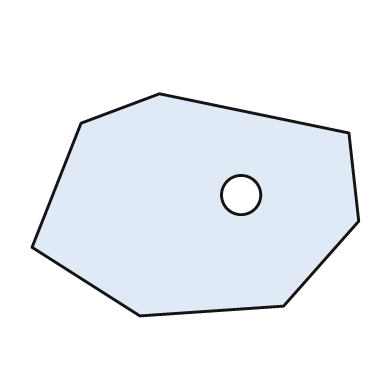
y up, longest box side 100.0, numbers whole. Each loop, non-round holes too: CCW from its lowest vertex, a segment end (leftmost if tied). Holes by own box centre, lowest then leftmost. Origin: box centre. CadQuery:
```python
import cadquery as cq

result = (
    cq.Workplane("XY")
    .moveTo(-17.0, -34.0)
    .lineTo(27.0, -31.0)
    .lineTo(50.0, -5.0)
    .lineTo(47.0, 22.0)
    .lineTo(-11.0, 34.0)
    .lineTo(-35.0, 25.0)
    .lineTo(-50.0, -13.0)
    .close()
    .moveTo(14.0, 3.0)
    .circle(6.0)
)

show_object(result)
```